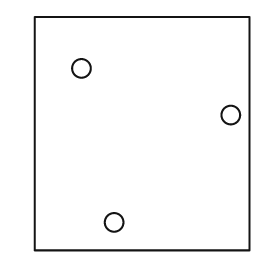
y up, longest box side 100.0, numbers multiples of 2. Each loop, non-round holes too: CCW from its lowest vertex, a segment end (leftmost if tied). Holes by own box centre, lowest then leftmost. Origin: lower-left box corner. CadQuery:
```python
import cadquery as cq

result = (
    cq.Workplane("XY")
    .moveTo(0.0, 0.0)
    .lineTo(92.0, 0.0)
    .lineTo(92.0, 100.0)
    .lineTo(0.0, 100.0)
    .close()
    .moveTo(34.0, 12.0)
    .circle(4.0)
    .moveTo(84.0, 58.0)
    .circle(4.0)
    .moveTo(20.0, 78.0)
    .circle(4.0)
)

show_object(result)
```